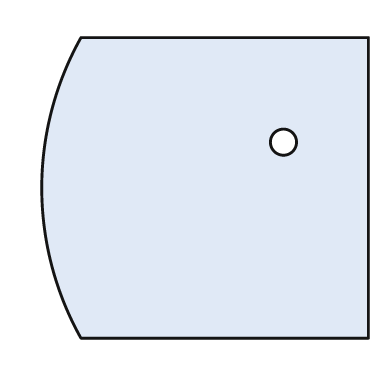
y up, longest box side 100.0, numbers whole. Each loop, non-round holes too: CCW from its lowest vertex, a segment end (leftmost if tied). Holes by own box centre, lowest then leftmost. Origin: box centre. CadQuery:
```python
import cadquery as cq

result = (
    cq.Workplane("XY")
    .moveTo(-38.0, -46.0)
    .lineTo(50.0, -46.0)
    .lineTo(50.0, 46.0)
    .lineTo(-38.0, 46.0)
    .threePointArc((-50.0, 0.0), (-38.0, -46.0))
    .close()
    .moveTo(24.0, 14.0)
    .circle(4.0)
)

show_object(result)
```